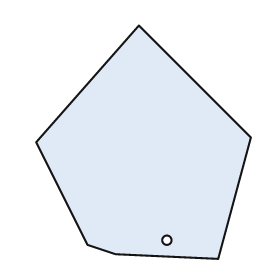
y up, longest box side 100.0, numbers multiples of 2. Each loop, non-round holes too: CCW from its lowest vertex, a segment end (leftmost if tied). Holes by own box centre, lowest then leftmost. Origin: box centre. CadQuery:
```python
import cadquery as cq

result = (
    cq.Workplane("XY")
    .moveTo(32.0, -50.0)
    .lineTo(46.0, 2.0)
    .lineTo(-2.0, 50.0)
    .lineTo(-46.0, 0.0)
    .lineTo(-24.0, -44.0)
    .lineTo(-12.0, -48.0)
    .close()
    .moveTo(10.0, -42.0)
    .circle(2.0)
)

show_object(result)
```